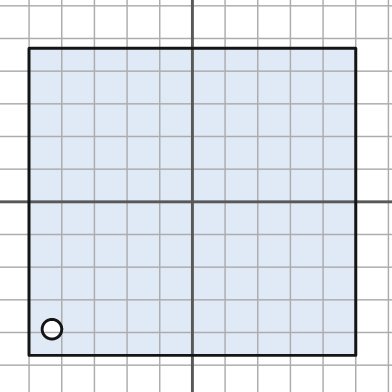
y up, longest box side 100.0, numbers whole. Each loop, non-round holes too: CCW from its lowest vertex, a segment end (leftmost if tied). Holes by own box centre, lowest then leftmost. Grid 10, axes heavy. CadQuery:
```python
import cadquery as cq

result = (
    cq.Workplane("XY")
    .moveTo(-50.0, -47.0)
    .lineTo(50.0, -47.0)
    .lineTo(50.0, 47.0)
    .lineTo(-50.0, 47.0)
    .close()
    .moveTo(-43.0, -39.0)
    .circle(3.0)
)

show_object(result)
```